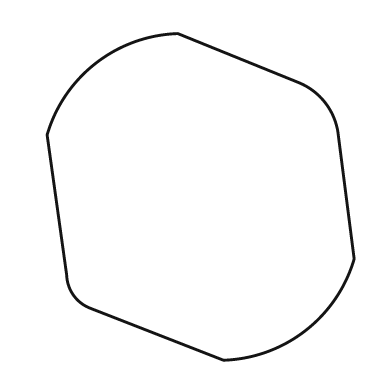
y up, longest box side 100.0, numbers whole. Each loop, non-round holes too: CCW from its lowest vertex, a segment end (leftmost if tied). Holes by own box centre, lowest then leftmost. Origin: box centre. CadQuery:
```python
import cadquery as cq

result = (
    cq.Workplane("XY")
    .moveTo(7.0, -50.0)
    .threePointArc((32.0, -41.0), (47.0, -19.0))
    .lineTo(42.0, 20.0)
    .threePointArc((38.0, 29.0), (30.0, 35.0))
    .lineTo(-7.0, 50.0)
    .threePointArc((-32.0, 41.0), (-47.0, 19.0))
    .lineTo(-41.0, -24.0)
    .threePointArc((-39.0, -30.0), (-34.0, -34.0))
    .close()
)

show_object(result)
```